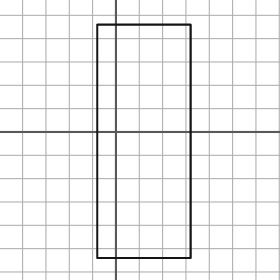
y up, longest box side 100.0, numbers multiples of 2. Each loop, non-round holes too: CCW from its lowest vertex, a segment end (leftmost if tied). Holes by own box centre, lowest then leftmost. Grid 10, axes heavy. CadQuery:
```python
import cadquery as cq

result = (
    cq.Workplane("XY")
    .moveTo(-8.0, -54.0)
    .lineTo(32.0, -54.0)
    .lineTo(32.0, 46.0)
    .lineTo(-8.0, 46.0)
    .close()
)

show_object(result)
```